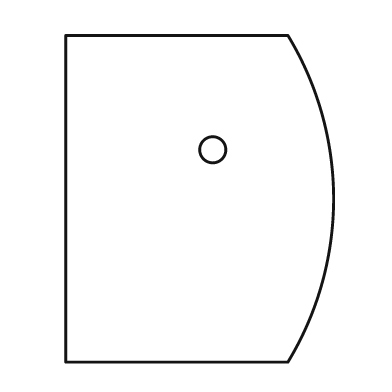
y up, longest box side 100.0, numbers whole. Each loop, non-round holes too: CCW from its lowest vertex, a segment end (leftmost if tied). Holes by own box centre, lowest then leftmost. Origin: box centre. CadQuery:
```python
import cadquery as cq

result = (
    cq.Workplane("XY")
    .moveTo(-41.0, -50.0)
    .lineTo(27.0, -50.0)
    .threePointArc((41.0, 0.0), (27.0, 50.0))
    .lineTo(-41.0, 50.0)
    .close()
    .moveTo(4.0, 15.0)
    .circle(4.0)
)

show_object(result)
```